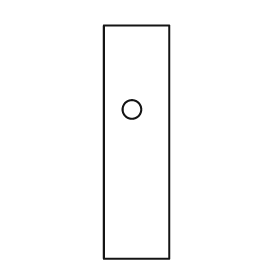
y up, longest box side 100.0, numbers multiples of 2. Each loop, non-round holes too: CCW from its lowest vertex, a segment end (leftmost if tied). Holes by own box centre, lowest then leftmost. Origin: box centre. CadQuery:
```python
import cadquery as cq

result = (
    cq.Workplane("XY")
    .moveTo(-14.0, -50.0)
    .lineTo(14.0, -50.0)
    .lineTo(14.0, 50.0)
    .lineTo(-14.0, 50.0)
    .close()
    .moveTo(-2.0, 14.0)
    .circle(4.0)
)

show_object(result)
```